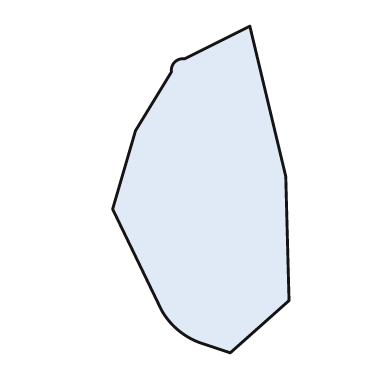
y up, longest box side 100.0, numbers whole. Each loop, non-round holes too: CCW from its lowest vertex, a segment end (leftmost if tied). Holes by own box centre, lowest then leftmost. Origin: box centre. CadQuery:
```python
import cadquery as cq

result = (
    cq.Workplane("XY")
    .moveTo(9.0, -50.0)
    .lineTo(27.0, -34.0)
    .lineTo(26.0, 4.0)
    .lineTo(15.0, 50.0)
    .lineTo(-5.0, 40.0)
    .threePointArc((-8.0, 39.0), (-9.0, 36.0))
    .lineTo(-20.0, 18.0)
    .lineTo(-27.0, -6.0)
    .lineTo(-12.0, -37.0)
    .threePointArc((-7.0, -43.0), (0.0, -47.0))
    .close()
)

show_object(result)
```